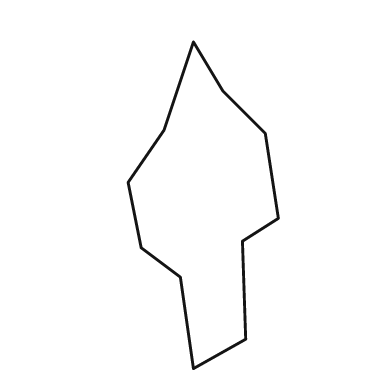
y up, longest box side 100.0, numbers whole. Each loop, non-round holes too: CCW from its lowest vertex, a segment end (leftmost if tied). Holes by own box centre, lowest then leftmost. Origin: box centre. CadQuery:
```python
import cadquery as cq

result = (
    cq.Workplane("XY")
    .moveTo(-3.0, -50.0)
    .lineTo(13.0, -41.0)
    .lineTo(12.0, -11.0)
    .lineTo(23.0, -4.0)
    .lineTo(19.0, 22.0)
    .lineTo(6.0, 35.0)
    .lineTo(-3.0, 50.0)
    .lineTo(-12.0, 23.0)
    .lineTo(-23.0, 7.0)
    .lineTo(-19.0, -13.0)
    .lineTo(-7.0, -22.0)
    .close()
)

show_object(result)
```